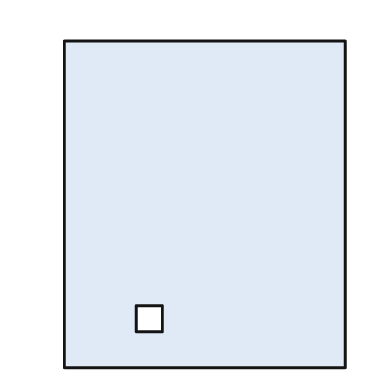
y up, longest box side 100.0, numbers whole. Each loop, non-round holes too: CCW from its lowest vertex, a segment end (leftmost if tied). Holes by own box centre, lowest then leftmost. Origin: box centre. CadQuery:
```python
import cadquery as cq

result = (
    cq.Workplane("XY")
    .moveTo(-43.0, -50.0)
    .lineTo(43.0, -50.0)
    .lineTo(43.0, 50.0)
    .lineTo(-43.0, 50.0)
    .close()
    .moveTo(-21.0, -39.0)
    .lineTo(-13.0, -39.0)
    .lineTo(-13.0, -31.0)
    .lineTo(-21.0, -31.0)
    .close()
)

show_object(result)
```